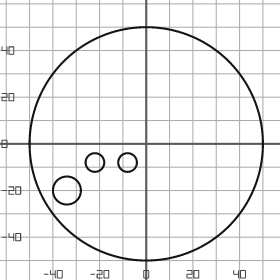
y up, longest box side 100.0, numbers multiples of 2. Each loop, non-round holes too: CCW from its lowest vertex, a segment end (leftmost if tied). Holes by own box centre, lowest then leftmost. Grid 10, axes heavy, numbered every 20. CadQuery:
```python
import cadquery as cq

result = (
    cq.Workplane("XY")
    .moveTo(0.0, 0.0)
    .circle(50.0)
    .moveTo(-34.0, -20.0)
    .circle(6.0)
    .moveTo(-22.0, -8.0)
    .circle(4.0)
    .moveTo(-8.0, -8.0)
    .circle(4.0)
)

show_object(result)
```